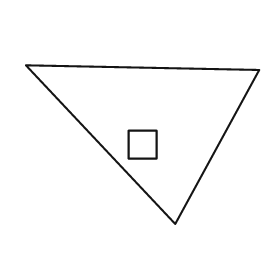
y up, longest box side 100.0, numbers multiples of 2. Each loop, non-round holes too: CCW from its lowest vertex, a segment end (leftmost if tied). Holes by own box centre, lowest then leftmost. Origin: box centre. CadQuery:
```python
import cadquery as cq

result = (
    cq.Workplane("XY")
    .moveTo(14.0, -34.0)
    .lineTo(50.0, 32.0)
    .lineTo(-50.0, 34.0)
    .close()
    .moveTo(-6.0, -6.0)
    .lineTo(6.0, -6.0)
    .lineTo(6.0, 6.0)
    .lineTo(-6.0, 6.0)
    .close()
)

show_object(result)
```